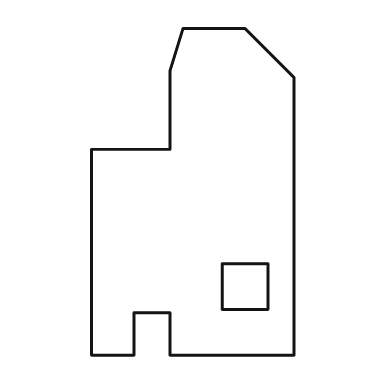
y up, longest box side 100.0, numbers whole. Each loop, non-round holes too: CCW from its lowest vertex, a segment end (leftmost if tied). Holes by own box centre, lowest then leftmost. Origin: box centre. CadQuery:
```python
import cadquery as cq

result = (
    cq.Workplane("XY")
    .moveTo(-31.0, -50.0)
    .lineTo(-18.0, -50.0)
    .lineTo(-18.0, -37.0)
    .lineTo(-7.0, -37.0)
    .lineTo(-7.0, -50.0)
    .lineTo(31.0, -50.0)
    .lineTo(31.0, 35.0)
    .lineTo(16.0, 50.0)
    .lineTo(-3.0, 50.0)
    .lineTo(-7.0, 37.0)
    .lineTo(-7.0, 13.0)
    .lineTo(-31.0, 13.0)
    .close()
    .moveTo(9.0, -36.0)
    .lineTo(23.0, -36.0)
    .lineTo(23.0, -22.0)
    .lineTo(9.0, -22.0)
    .close()
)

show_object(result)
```